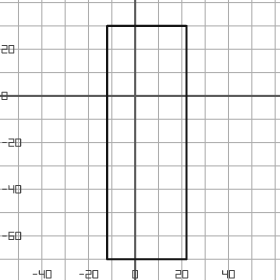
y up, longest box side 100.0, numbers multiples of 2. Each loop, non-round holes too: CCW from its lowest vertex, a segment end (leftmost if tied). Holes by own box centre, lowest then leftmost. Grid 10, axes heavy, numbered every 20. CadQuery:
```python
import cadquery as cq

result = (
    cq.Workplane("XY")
    .moveTo(-12.0, -70.0)
    .lineTo(22.0, -70.0)
    .lineTo(22.0, 30.0)
    .lineTo(-12.0, 30.0)
    .close()
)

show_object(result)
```